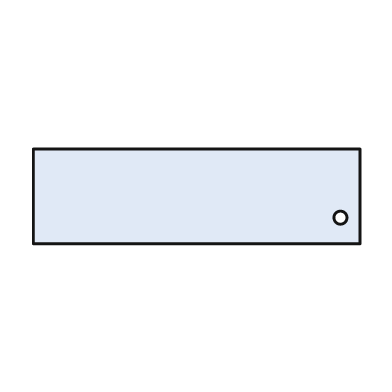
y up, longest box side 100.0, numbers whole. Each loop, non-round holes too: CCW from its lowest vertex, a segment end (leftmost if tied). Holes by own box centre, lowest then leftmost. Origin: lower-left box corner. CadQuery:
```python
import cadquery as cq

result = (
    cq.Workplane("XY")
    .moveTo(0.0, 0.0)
    .lineTo(100.0, 0.0)
    .lineTo(100.0, 29.0)
    .lineTo(0.0, 29.0)
    .close()
    .moveTo(94.0, 8.0)
    .circle(2.0)
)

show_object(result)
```